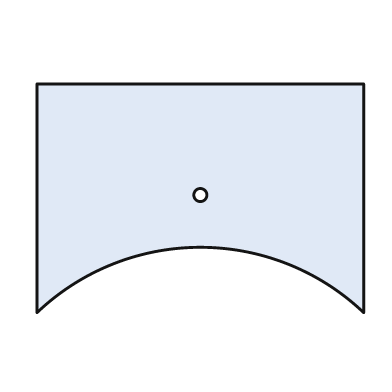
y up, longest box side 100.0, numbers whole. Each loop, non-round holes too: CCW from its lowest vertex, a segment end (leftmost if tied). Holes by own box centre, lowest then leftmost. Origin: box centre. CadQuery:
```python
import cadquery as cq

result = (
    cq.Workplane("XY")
    .moveTo(-50.0, -35.0)
    .threePointArc((0.0, -15.0), (50.0, -35.0))
    .lineTo(50.0, 35.0)
    .lineTo(-50.0, 35.0)
    .close()
    .moveTo(0.0, 1.0)
    .circle(2.0)
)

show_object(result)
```